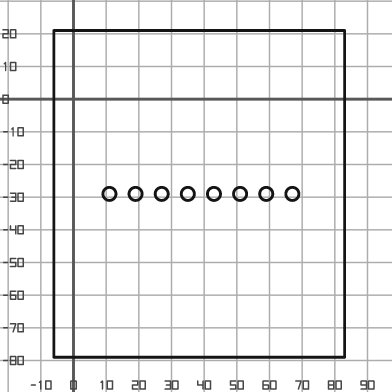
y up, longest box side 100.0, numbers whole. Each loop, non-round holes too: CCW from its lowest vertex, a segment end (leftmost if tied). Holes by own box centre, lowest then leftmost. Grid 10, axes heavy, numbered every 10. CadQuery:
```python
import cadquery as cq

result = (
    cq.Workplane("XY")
    .moveTo(-6.0, -79.0)
    .lineTo(83.0, -79.0)
    .lineTo(83.0, 21.0)
    .lineTo(-6.0, 21.0)
    .close()
    .moveTo(11.0, -29.0)
    .circle(2.0)
    .moveTo(19.0, -29.0)
    .circle(2.0)
    .moveTo(27.0, -29.0)
    .circle(2.0)
    .moveTo(35.0, -29.0)
    .circle(2.0)
    .moveTo(43.0, -29.0)
    .circle(2.0)
    .moveTo(51.0, -29.0)
    .circle(2.0)
    .moveTo(59.0, -29.0)
    .circle(2.0)
    .moveTo(67.0, -29.0)
    .circle(2.0)
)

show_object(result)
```